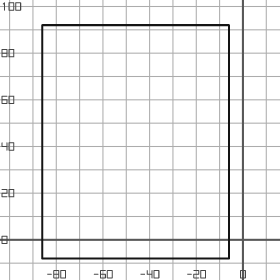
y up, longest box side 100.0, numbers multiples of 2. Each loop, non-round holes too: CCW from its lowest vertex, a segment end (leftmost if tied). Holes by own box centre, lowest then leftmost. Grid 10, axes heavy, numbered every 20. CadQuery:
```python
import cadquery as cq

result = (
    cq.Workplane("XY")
    .moveTo(-86.0, -8.0)
    .lineTo(-6.0, -8.0)
    .lineTo(-6.0, 92.0)
    .lineTo(-86.0, 92.0)
    .close()
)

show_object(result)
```